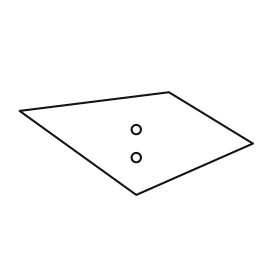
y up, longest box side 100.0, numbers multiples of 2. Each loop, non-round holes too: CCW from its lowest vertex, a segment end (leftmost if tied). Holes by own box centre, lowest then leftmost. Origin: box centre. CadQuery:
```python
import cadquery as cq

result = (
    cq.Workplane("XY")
    .moveTo(0.0, -22.0)
    .lineTo(50.0, 0.0)
    .lineTo(14.0, 22.0)
    .lineTo(-50.0, 14.0)
    .close()
    .moveTo(0.0, -6.0)
    .circle(2.0)
    .moveTo(0.0, 6.0)
    .circle(2.0)
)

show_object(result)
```